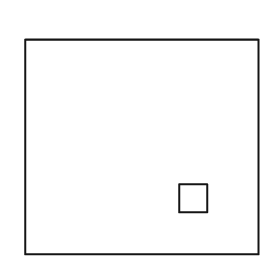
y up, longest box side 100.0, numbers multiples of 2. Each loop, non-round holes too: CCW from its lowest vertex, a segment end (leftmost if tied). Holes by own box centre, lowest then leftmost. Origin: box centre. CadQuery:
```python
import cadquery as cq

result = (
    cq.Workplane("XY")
    .moveTo(-50.0, -46.0)
    .lineTo(50.0, -46.0)
    .lineTo(50.0, 46.0)
    .lineTo(-50.0, 46.0)
    .close()
    .moveTo(16.0, -28.0)
    .lineTo(28.0, -28.0)
    .lineTo(28.0, -16.0)
    .lineTo(16.0, -16.0)
    .close()
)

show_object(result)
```